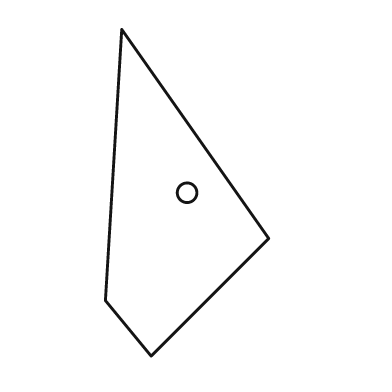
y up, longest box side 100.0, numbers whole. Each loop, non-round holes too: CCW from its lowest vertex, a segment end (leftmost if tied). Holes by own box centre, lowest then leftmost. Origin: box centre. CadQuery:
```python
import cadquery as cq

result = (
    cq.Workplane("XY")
    .moveTo(-11.0, -50.0)
    .lineTo(25.0, -14.0)
    .lineTo(-20.0, 50.0)
    .lineTo(-25.0, -33.0)
    .close()
    .moveTo(0.0, 0.0)
    .circle(3.0)
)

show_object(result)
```